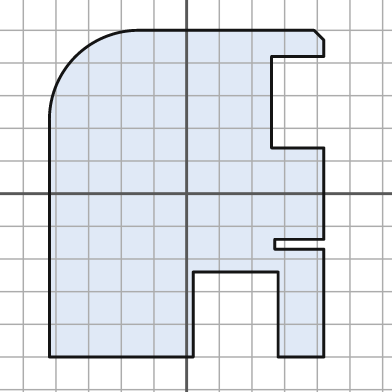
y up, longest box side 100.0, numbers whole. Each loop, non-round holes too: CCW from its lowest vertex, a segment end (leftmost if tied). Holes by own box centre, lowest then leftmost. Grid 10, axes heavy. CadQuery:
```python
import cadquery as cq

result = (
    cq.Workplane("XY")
    .moveTo(-42.0, -50.0)
    .lineTo(2.0, -50.0)
    .lineTo(2.0, -24.0)
    .lineTo(28.0, -24.0)
    .lineTo(28.0, -50.0)
    .lineTo(42.0, -50.0)
    .lineTo(42.0, -17.0)
    .lineTo(27.0, -17.0)
    .lineTo(27.0, -14.0)
    .lineTo(42.0, -14.0)
    .lineTo(42.0, 14.0)
    .lineTo(26.0, 14.0)
    .lineTo(26.0, 42.0)
    .lineTo(42.0, 42.0)
    .lineTo(42.0, 47.0)
    .lineTo(39.0, 50.0)
    .lineTo(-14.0, 50.0)
    .threePointArc((-34.0, 42.0), (-42.0, 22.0))
    .close()
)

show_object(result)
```